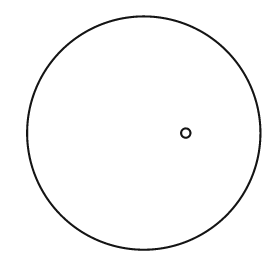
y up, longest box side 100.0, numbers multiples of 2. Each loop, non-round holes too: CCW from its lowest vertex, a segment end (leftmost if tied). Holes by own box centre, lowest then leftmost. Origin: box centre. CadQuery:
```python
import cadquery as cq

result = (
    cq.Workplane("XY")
    .moveTo(0.0, 0.0)
    .circle(50.0)
    .moveTo(18.0, 0.0)
    .circle(2.0)
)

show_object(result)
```